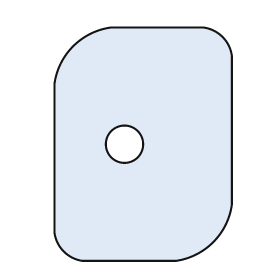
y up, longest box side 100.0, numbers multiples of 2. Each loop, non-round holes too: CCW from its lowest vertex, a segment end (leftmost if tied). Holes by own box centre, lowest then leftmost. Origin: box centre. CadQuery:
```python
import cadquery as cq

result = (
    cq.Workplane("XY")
    .moveTo(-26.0, -50.0)
    .lineTo(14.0, -50.0)
    .threePointArc((30.0, -42.0), (38.0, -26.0))
    .lineTo(38.0, 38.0)
    .threePointArc((34.0, 46.0), (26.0, 50.0))
    .lineTo(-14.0, 50.0)
    .threePointArc((-30.0, 42.0), (-38.0, 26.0))
    .lineTo(-38.0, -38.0)
    .threePointArc((-34.0, -46.0), (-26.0, -50.0))
    .close()
    .moveTo(-8.0, 0.0)
    .circle(8.0)
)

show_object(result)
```